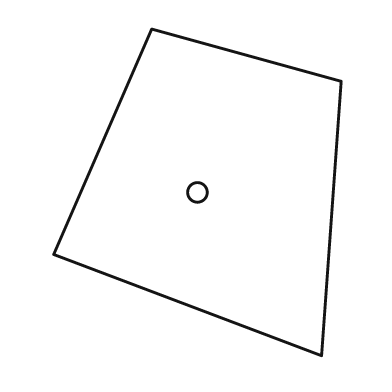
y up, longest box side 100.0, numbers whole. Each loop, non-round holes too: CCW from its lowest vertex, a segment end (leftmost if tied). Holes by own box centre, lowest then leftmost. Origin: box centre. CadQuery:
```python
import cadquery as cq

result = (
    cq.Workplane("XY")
    .moveTo(38.0, -50.0)
    .lineTo(44.0, 34.0)
    .lineTo(-14.0, 50.0)
    .lineTo(-44.0, -19.0)
    .close()
    .moveTo(0.0, 0.0)
    .circle(3.0)
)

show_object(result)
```